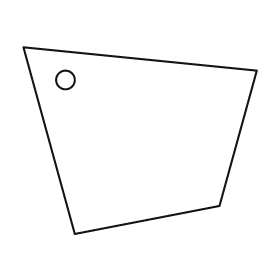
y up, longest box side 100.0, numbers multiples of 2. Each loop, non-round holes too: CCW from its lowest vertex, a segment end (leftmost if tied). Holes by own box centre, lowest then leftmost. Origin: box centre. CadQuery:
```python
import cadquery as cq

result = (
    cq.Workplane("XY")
    .moveTo(-28.0, -40.0)
    .lineTo(34.0, -28.0)
    .lineTo(50.0, 30.0)
    .lineTo(-50.0, 40.0)
    .close()
    .moveTo(-32.0, 26.0)
    .circle(4.0)
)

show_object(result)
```